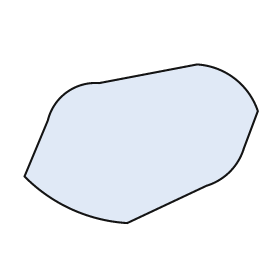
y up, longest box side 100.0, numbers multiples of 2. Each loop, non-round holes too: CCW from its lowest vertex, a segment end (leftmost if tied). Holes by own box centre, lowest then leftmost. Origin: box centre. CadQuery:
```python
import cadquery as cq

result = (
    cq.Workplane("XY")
    .moveTo(-6.0, -34.0)
    .lineTo(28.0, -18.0)
    .threePointArc((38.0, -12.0), (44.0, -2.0))
    .lineTo(50.0, 14.0)
    .threePointArc((40.0, 28.0), (24.0, 34.0))
    .lineTo(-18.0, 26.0)
    .threePointArc((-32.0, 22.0), (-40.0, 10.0))
    .lineTo(-50.0, -14.0)
    .threePointArc((-30.0, -28.0), (-6.0, -34.0))
    .close()
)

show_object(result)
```